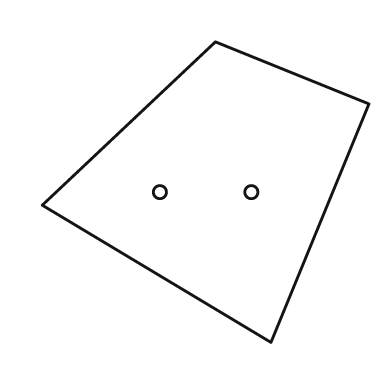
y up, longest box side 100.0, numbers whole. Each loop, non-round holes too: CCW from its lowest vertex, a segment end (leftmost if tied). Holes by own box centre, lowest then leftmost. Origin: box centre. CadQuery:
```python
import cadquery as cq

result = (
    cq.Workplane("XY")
    .moveTo(20.0, -46.0)
    .lineTo(50.0, 27.0)
    .lineTo(3.0, 46.0)
    .lineTo(-50.0, -4.0)
    .close()
    .moveTo(-14.0, 0.0)
    .circle(2.0)
    .moveTo(14.0, 0.0)
    .circle(2.0)
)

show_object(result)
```